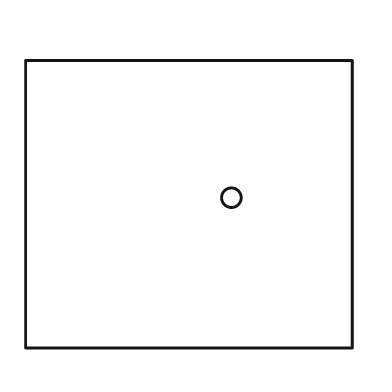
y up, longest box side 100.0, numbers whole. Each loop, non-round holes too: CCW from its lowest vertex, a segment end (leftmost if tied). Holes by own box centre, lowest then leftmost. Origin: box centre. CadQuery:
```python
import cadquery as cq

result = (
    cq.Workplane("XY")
    .moveTo(-50.0, -44.0)
    .lineTo(50.0, -44.0)
    .lineTo(50.0, 44.0)
    .lineTo(-50.0, 44.0)
    .close()
    .moveTo(13.0, 2.0)
    .circle(3.0)
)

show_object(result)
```